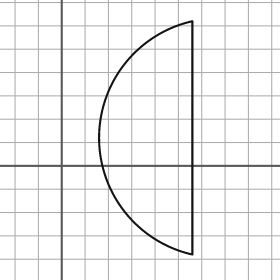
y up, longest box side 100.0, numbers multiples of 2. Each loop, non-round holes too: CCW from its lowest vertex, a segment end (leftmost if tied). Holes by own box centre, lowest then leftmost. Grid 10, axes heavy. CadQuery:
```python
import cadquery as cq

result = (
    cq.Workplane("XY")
    .moveTo(56.0, -38.0)
    .lineTo(56.0, 62.0)
    .threePointArc((16.0, 12.0), (56.0, -38.0))
    .close()
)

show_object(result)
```